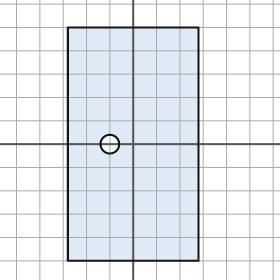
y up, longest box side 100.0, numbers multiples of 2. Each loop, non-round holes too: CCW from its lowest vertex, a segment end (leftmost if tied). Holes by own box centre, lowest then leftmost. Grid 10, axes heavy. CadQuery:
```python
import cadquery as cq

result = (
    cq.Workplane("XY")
    .moveTo(-28.0, -50.0)
    .lineTo(28.0, -50.0)
    .lineTo(28.0, 50.0)
    .lineTo(-28.0, 50.0)
    .close()
    .moveTo(-10.0, 0.0)
    .circle(4.0)
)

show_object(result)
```